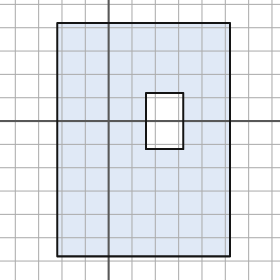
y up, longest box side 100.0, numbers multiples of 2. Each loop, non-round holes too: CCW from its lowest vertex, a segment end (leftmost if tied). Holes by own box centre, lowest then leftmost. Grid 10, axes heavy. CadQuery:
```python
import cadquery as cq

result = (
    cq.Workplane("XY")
    .moveTo(-22.0, -58.0)
    .lineTo(52.0, -58.0)
    .lineTo(52.0, 42.0)
    .lineTo(-22.0, 42.0)
    .close()
    .moveTo(16.0, -12.0)
    .lineTo(32.0, -12.0)
    .lineTo(32.0, 12.0)
    .lineTo(16.0, 12.0)
    .close()
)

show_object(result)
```